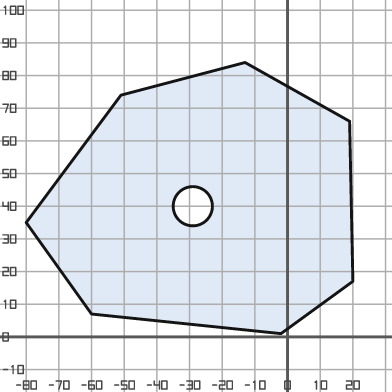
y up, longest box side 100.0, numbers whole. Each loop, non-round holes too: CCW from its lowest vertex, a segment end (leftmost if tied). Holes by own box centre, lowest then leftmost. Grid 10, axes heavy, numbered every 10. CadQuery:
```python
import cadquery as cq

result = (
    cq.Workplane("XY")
    .moveTo(-2.0, 1.0)
    .lineTo(20.0, 17.0)
    .lineTo(19.0, 66.0)
    .lineTo(-13.0, 84.0)
    .lineTo(-51.0, 74.0)
    .lineTo(-80.0, 35.0)
    .lineTo(-60.0, 7.0)
    .close()
    .moveTo(-29.0, 40.0)
    .circle(6.0)
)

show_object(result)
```